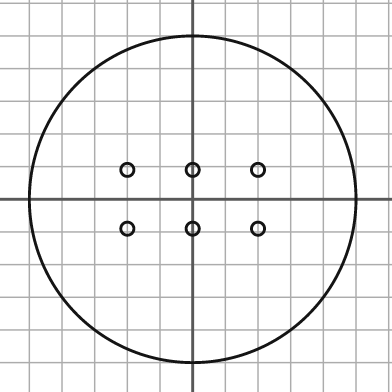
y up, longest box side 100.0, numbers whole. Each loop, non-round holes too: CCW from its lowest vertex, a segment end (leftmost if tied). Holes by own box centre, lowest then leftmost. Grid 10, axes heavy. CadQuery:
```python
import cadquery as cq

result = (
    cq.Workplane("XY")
    .moveTo(0.0, 0.0)
    .circle(50.0)
    .moveTo(-20.0, -9.0)
    .circle(2.0)
    .moveTo(0.0, -9.0)
    .circle(2.0)
    .moveTo(20.0, -9.0)
    .circle(2.0)
    .moveTo(-20.0, 9.0)
    .circle(2.0)
    .moveTo(0.0, 9.0)
    .circle(2.0)
    .moveTo(20.0, 9.0)
    .circle(2.0)
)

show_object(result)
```